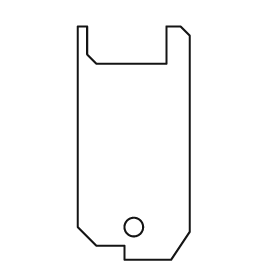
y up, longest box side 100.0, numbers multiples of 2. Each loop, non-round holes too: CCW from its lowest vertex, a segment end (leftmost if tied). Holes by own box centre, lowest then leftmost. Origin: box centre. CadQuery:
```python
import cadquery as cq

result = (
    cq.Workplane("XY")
    .moveTo(-4.0, -50.0)
    .lineTo(16.0, -50.0)
    .lineTo(24.0, -38.0)
    .lineTo(24.0, 46.0)
    .lineTo(20.0, 50.0)
    .lineTo(14.0, 50.0)
    .lineTo(14.0, 34.0)
    .lineTo(-16.0, 34.0)
    .lineTo(-20.0, 38.0)
    .lineTo(-20.0, 50.0)
    .lineTo(-24.0, 50.0)
    .lineTo(-24.0, -36.0)
    .lineTo(-16.0, -44.0)
    .lineTo(-4.0, -44.0)
    .close()
    .moveTo(0.0, -36.0)
    .circle(4.0)
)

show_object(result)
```